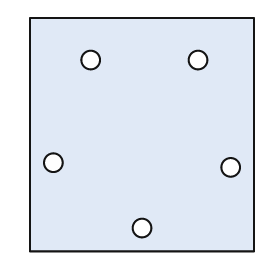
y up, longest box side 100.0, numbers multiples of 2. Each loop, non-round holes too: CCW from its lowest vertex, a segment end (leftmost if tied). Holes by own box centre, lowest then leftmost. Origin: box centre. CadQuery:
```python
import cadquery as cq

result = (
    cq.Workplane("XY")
    .moveTo(-48.0, -50.0)
    .lineTo(48.0, -50.0)
    .lineTo(48.0, 50.0)
    .lineTo(-48.0, 50.0)
    .close()
    .moveTo(0.0, -40.0)
    .circle(4.0)
    .moveTo(38.0, -14.0)
    .circle(4.0)
    .moveTo(-38.0, -12.0)
    .circle(4.0)
    .moveTo(-22.0, 32.0)
    .circle(4.0)
    .moveTo(24.0, 32.0)
    .circle(4.0)
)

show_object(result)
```